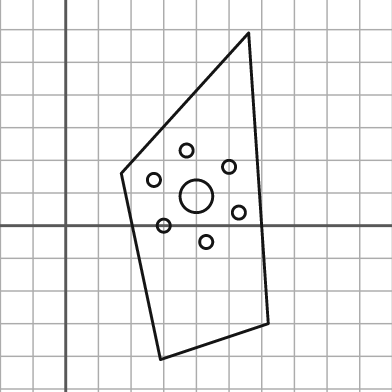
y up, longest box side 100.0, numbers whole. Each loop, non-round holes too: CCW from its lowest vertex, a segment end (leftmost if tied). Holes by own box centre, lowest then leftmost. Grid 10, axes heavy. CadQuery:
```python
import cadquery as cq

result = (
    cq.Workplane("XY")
    .moveTo(29.0, -41.0)
    .lineTo(62.0, -30.0)
    .lineTo(56.0, 59.0)
    .lineTo(17.0, 16.0)
    .close()
    .moveTo(43.0, -5.0)
    .circle(2.0)
    .moveTo(30.0, 0.0)
    .circle(2.0)
    .moveTo(53.0, 4.0)
    .circle(2.0)
    .moveTo(40.0, 9.0)
    .circle(5.0)
    .moveTo(27.0, 14.0)
    .circle(2.0)
    .moveTo(50.0, 18.0)
    .circle(2.0)
    .moveTo(37.0, 23.0)
    .circle(2.0)
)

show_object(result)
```